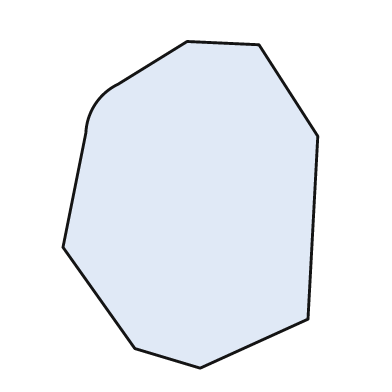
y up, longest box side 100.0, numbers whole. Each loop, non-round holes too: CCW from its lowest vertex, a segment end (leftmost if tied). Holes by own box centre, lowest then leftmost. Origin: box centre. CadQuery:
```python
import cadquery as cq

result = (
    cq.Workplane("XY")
    .moveTo(3.0, -50.0)
    .lineTo(36.0, -35.0)
    .lineTo(39.0, 21.0)
    .lineTo(21.0, 49.0)
    .lineTo(-1.0, 50.0)
    .lineTo(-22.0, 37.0)
    .threePointArc((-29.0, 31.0), (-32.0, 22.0))
    .lineTo(-39.0, -13.0)
    .lineTo(-17.0, -44.0)
    .close()
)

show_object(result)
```